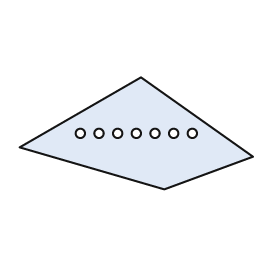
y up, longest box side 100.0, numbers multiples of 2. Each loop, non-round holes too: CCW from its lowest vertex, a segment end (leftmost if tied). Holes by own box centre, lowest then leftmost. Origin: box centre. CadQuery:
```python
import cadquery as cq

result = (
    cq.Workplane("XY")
    .moveTo(12.0, -24.0)
    .lineTo(50.0, -10.0)
    .lineTo(2.0, 24.0)
    .lineTo(-50.0, -6.0)
    .close()
    .moveTo(-24.0, 0.0)
    .circle(2.0)
    .moveTo(-16.0, 0.0)
    .circle(2.0)
    .moveTo(-8.0, 0.0)
    .circle(2.0)
    .moveTo(0.0, 0.0)
    .circle(2.0)
    .moveTo(8.0, 0.0)
    .circle(2.0)
    .moveTo(16.0, 0.0)
    .circle(2.0)
    .moveTo(24.0, 0.0)
    .circle(2.0)
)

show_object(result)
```